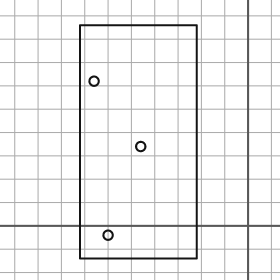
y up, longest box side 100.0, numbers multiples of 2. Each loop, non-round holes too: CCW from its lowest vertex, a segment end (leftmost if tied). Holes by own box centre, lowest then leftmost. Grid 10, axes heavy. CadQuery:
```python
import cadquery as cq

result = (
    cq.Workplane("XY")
    .moveTo(-72.0, -14.0)
    .lineTo(-22.0, -14.0)
    .lineTo(-22.0, 86.0)
    .lineTo(-72.0, 86.0)
    .close()
    .moveTo(-60.0, -4.0)
    .circle(2.0)
    .moveTo(-46.0, 34.0)
    .circle(2.0)
    .moveTo(-66.0, 62.0)
    .circle(2.0)
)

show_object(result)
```